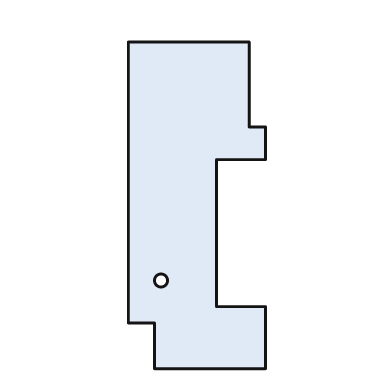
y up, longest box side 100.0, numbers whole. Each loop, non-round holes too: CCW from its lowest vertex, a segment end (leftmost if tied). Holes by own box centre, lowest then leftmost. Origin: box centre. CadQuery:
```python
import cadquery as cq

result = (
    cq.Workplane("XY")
    .moveTo(-13.0, -50.0)
    .lineTo(21.0, -50.0)
    .lineTo(21.0, -31.0)
    .lineTo(6.0, -31.0)
    .lineTo(6.0, 14.0)
    .lineTo(21.0, 14.0)
    .lineTo(21.0, 24.0)
    .lineTo(16.0, 24.0)
    .lineTo(16.0, 50.0)
    .lineTo(-21.0, 50.0)
    .lineTo(-21.0, -36.0)
    .lineTo(-13.0, -36.0)
    .close()
    .moveTo(-11.0, -23.0)
    .circle(2.0)
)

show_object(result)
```